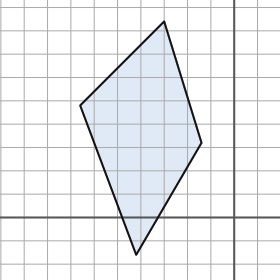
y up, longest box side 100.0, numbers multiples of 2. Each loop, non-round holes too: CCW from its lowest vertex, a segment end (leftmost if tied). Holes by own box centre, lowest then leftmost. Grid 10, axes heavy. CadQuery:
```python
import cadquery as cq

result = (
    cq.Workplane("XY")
    .moveTo(-42.0, -16.0)
    .lineTo(-14.0, 32.0)
    .lineTo(-30.0, 84.0)
    .lineTo(-66.0, 48.0)
    .close()
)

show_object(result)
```